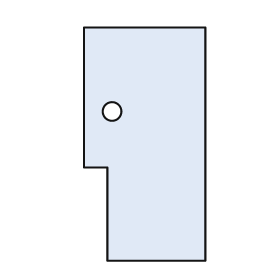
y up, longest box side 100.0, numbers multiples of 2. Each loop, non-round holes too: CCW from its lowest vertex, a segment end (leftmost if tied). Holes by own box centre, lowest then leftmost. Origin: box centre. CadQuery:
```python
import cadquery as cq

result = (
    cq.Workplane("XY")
    .moveTo(-16.0, -50.0)
    .lineTo(26.0, -50.0)
    .lineTo(26.0, 50.0)
    .lineTo(-26.0, 50.0)
    .lineTo(-26.0, -10.0)
    .lineTo(-16.0, -10.0)
    .close()
    .moveTo(-14.0, 14.0)
    .circle(4.0)
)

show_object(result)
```